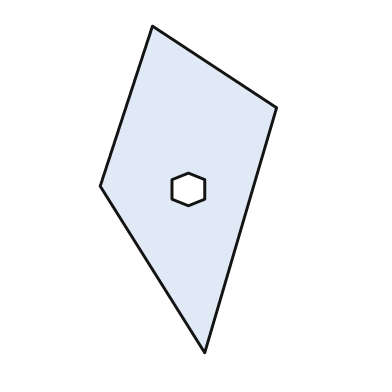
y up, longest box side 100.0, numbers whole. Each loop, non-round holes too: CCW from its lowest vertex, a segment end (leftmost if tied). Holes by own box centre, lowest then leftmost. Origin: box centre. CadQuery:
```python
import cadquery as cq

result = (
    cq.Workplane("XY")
    .moveTo(5.0, -50.0)
    .lineTo(27.0, 25.0)
    .lineTo(-11.0, 50.0)
    .lineTo(-27.0, 1.0)
    .close()
    .moveTo(0.0, -5.0)
    .lineTo(5.0, -3.0)
    .lineTo(5.0, 3.0)
    .lineTo(0.0, 5.0)
    .lineTo(-5.0, 3.0)
    .lineTo(-5.0, -3.0)
    .close()
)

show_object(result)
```